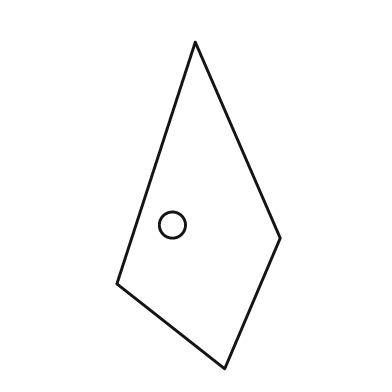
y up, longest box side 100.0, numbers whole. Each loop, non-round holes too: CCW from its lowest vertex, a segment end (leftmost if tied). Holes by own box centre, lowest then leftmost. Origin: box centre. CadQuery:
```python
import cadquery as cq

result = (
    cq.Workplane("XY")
    .moveTo(8.0, -50.0)
    .lineTo(25.0, -10.0)
    .lineTo(-1.0, 50.0)
    .lineTo(-25.0, -24.0)
    .close()
    .moveTo(-8.0, -6.0)
    .circle(4.0)
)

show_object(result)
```